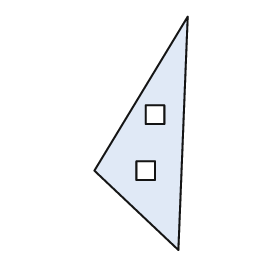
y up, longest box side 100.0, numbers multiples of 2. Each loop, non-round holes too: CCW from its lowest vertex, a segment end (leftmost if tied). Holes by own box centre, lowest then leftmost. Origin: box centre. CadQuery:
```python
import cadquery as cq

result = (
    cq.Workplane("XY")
    .moveTo(16.0, -50.0)
    .lineTo(20.0, 50.0)
    .lineTo(-20.0, -16.0)
    .close()
    .moveTo(-2.0, -20.0)
    .lineTo(6.0, -20.0)
    .lineTo(6.0, -12.0)
    .lineTo(-2.0, -12.0)
    .close()
    .moveTo(2.0, 4.0)
    .lineTo(10.0, 4.0)
    .lineTo(10.0, 12.0)
    .lineTo(2.0, 12.0)
    .close()
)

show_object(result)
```